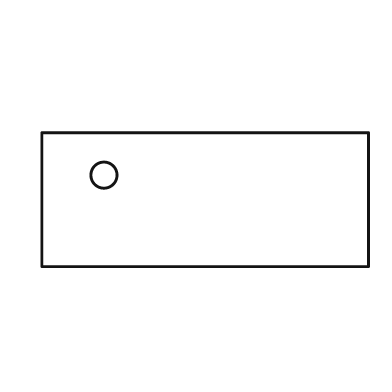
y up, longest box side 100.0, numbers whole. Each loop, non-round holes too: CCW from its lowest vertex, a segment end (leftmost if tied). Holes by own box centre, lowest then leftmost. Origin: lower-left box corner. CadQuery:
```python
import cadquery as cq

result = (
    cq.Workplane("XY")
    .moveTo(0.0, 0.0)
    .lineTo(100.0, 0.0)
    .lineTo(100.0, 41.0)
    .lineTo(0.0, 41.0)
    .close()
    .moveTo(19.0, 28.0)
    .circle(4.0)
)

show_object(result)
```